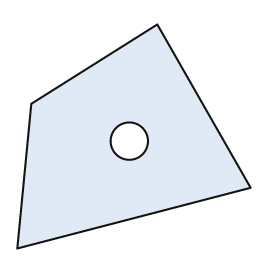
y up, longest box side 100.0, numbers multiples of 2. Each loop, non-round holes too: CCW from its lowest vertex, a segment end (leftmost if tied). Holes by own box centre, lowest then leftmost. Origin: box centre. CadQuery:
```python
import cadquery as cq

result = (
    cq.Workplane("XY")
    .moveTo(-50.0, -48.0)
    .lineTo(50.0, -22.0)
    .lineTo(10.0, 48.0)
    .lineTo(-44.0, 14.0)
    .close()
    .moveTo(-2.0, -2.0)
    .circle(8.0)
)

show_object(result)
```